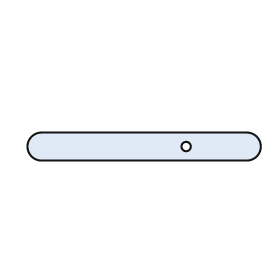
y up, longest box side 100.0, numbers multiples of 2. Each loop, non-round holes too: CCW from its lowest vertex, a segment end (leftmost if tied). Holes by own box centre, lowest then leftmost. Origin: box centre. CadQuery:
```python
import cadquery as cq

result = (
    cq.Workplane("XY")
    .moveTo(-44.0, -6.0)
    .lineTo(44.0, -6.0)
    .threePointArc((50.0, 0.0), (44.0, 6.0))
    .lineTo(-44.0, 6.0)
    .threePointArc((-50.0, 0.0), (-44.0, -6.0))
    .close()
    .moveTo(18.0, 0.0)
    .circle(2.0)
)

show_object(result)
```